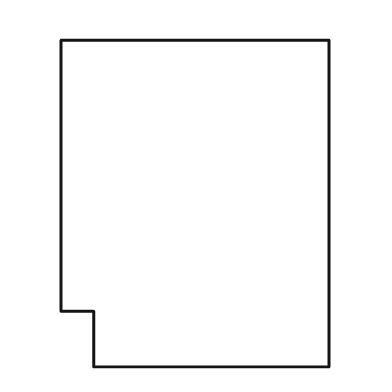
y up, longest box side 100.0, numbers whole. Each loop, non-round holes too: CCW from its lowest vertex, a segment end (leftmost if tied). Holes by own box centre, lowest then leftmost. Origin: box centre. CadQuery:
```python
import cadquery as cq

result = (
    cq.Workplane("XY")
    .moveTo(-31.0, -50.0)
    .lineTo(41.0, -50.0)
    .lineTo(41.0, 50.0)
    .lineTo(-41.0, 50.0)
    .lineTo(-41.0, -33.0)
    .lineTo(-31.0, -33.0)
    .close()
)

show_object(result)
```